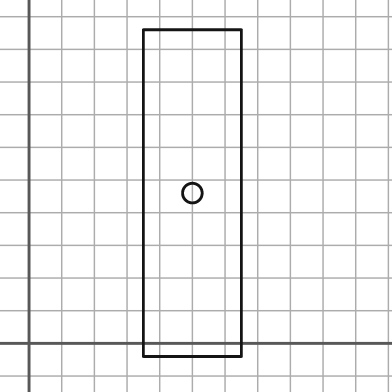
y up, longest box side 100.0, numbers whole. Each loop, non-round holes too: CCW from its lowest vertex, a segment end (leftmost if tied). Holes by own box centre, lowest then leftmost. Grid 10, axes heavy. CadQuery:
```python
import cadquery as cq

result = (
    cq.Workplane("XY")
    .moveTo(35.0, -4.0)
    .lineTo(65.0, -4.0)
    .lineTo(65.0, 96.0)
    .lineTo(35.0, 96.0)
    .close()
    .moveTo(50.0, 46.0)
    .circle(3.0)
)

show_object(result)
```